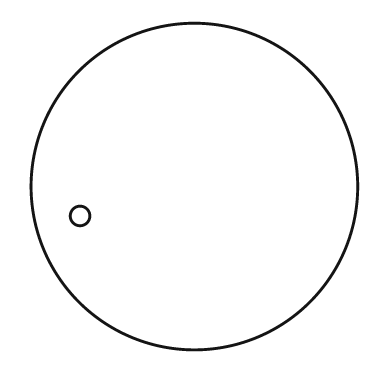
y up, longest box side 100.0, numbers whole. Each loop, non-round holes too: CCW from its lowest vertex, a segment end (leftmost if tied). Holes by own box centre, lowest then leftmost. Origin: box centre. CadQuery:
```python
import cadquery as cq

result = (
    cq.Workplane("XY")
    .moveTo(0.0, 0.0)
    .circle(50.0)
    .moveTo(-35.0, -9.0)
    .circle(3.0)
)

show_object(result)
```